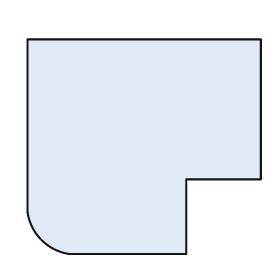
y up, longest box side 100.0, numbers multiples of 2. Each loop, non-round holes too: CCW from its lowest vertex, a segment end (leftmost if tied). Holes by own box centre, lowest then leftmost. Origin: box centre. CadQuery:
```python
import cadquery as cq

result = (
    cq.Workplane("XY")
    .moveTo(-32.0, -46.0)
    .lineTo(18.0, -46.0)
    .lineTo(18.0, -14.0)
    .lineTo(50.0, -14.0)
    .lineTo(50.0, 46.0)
    .lineTo(-50.0, 46.0)
    .lineTo(-50.0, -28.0)
    .threePointArc((-44.0, -40.0), (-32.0, -46.0))
    .close()
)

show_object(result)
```